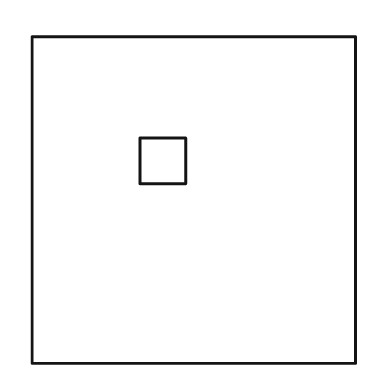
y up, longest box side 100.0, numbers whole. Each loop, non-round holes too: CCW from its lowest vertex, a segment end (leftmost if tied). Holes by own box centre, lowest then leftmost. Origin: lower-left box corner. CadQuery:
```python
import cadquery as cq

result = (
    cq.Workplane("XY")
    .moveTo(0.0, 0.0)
    .lineTo(99.0, 0.0)
    .lineTo(99.0, 100.0)
    .lineTo(0.0, 100.0)
    .close()
    .moveTo(33.0, 55.0)
    .lineTo(47.0, 55.0)
    .lineTo(47.0, 69.0)
    .lineTo(33.0, 69.0)
    .close()
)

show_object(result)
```